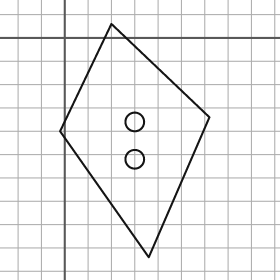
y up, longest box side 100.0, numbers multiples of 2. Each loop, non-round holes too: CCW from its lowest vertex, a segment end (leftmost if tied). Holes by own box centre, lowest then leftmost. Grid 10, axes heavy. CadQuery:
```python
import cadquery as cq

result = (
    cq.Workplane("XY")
    .moveTo(36.0, -94.0)
    .lineTo(62.0, -34.0)
    .lineTo(20.0, 6.0)
    .lineTo(-2.0, -40.0)
    .close()
    .moveTo(30.0, -52.0)
    .circle(4.0)
    .moveTo(30.0, -36.0)
    .circle(4.0)
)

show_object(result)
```